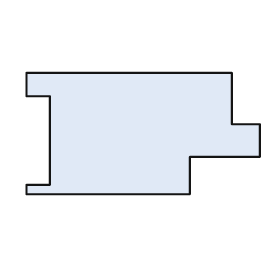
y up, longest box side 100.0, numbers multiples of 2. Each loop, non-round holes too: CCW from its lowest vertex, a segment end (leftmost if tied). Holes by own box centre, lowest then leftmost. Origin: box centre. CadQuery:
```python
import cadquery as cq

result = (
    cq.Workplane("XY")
    .moveTo(-50.0, -26.0)
    .lineTo(20.0, -26.0)
    .lineTo(20.0, -10.0)
    .lineTo(50.0, -10.0)
    .lineTo(50.0, 4.0)
    .lineTo(38.0, 4.0)
    .lineTo(38.0, 26.0)
    .lineTo(-50.0, 26.0)
    .lineTo(-50.0, 16.0)
    .lineTo(-40.0, 16.0)
    .lineTo(-40.0, -22.0)
    .lineTo(-50.0, -22.0)
    .close()
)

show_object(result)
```